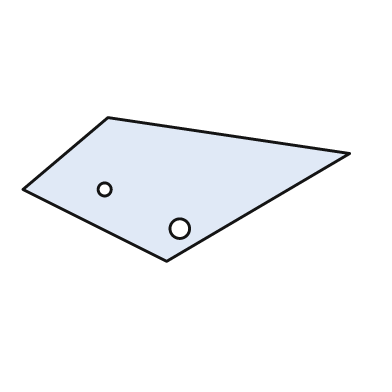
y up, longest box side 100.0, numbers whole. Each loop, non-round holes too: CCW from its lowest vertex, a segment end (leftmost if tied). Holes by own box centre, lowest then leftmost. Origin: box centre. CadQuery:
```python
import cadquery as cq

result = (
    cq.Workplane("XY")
    .moveTo(-6.0, -22.0)
    .lineTo(50.0, 11.0)
    .lineTo(-24.0, 22.0)
    .lineTo(-50.0, 0.0)
    .close()
    .moveTo(-2.0, -12.0)
    .circle(3.0)
    .moveTo(-25.0, 0.0)
    .circle(2.0)
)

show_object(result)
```